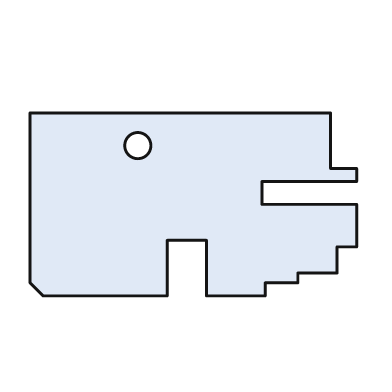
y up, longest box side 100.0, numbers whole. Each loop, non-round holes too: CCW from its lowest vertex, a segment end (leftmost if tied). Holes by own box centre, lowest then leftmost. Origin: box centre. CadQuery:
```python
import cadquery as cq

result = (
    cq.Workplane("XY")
    .moveTo(-46.0, -28.0)
    .lineTo(-8.0, -28.0)
    .lineTo(-8.0, -11.0)
    .lineTo(4.0, -11.0)
    .lineTo(4.0, -28.0)
    .lineTo(22.0, -28.0)
    .lineTo(22.0, -24.0)
    .lineTo(32.0, -24.0)
    .lineTo(32.0, -21.0)
    .lineTo(44.0, -21.0)
    .lineTo(44.0, -13.0)
    .lineTo(50.0, -13.0)
    .lineTo(50.0, 0.0)
    .lineTo(21.0, 0.0)
    .lineTo(21.0, 7.0)
    .lineTo(50.0, 7.0)
    .lineTo(50.0, 11.0)
    .lineTo(42.0, 11.0)
    .lineTo(42.0, 28.0)
    .lineTo(-50.0, 28.0)
    .lineTo(-50.0, -24.0)
    .close()
    .moveTo(-17.0, 18.0)
    .circle(4.0)
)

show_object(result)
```